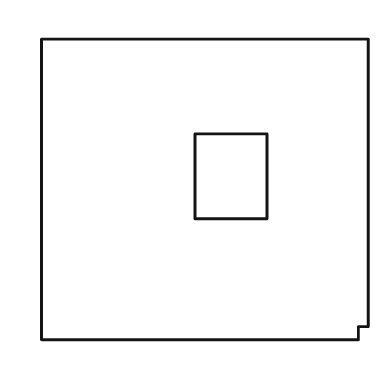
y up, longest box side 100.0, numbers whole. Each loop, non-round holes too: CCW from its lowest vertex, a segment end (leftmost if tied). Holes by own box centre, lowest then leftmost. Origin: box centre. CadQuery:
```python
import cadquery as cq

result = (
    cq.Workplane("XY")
    .moveTo(-50.0, -46.0)
    .lineTo(47.0, -46.0)
    .lineTo(47.0, -42.0)
    .lineTo(50.0, -42.0)
    .lineTo(50.0, 46.0)
    .lineTo(-50.0, 46.0)
    .close()
    .moveTo(-3.0, -9.0)
    .lineTo(19.0, -9.0)
    .lineTo(19.0, 17.0)
    .lineTo(-3.0, 17.0)
    .close()
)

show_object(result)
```